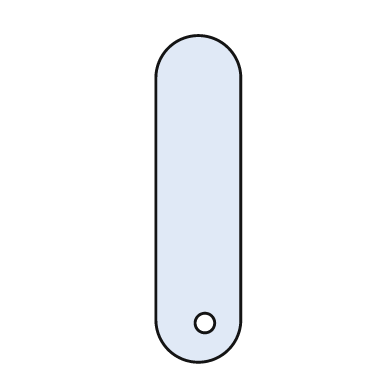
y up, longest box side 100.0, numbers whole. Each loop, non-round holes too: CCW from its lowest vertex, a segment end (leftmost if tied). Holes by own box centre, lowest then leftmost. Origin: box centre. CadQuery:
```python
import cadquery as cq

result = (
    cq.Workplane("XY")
    .moveTo(-13.0, -37.0)
    .threePointArc((0.0, -50.0), (13.0, -37.0))
    .lineTo(13.0, 37.0)
    .threePointArc((0.0, 50.0), (-13.0, 37.0))
    .close()
    .moveTo(2.0, -38.0)
    .circle(3.0)
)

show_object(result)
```